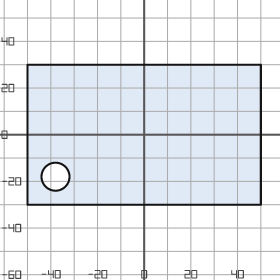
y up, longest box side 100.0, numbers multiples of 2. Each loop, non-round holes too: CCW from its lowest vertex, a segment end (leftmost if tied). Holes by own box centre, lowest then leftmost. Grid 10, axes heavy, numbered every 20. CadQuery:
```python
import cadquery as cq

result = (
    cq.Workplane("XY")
    .moveTo(-50.0, -30.0)
    .lineTo(50.0, -30.0)
    .lineTo(50.0, 30.0)
    .lineTo(-50.0, 30.0)
    .close()
    .moveTo(-38.0, -18.0)
    .circle(6.0)
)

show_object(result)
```